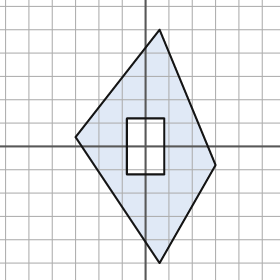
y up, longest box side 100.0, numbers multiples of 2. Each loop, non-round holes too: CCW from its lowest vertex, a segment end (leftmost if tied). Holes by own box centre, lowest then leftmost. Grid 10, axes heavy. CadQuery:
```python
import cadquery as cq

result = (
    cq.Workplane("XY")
    .moveTo(6.0, -50.0)
    .lineTo(30.0, -8.0)
    .lineTo(6.0, 50.0)
    .lineTo(-30.0, 4.0)
    .close()
    .moveTo(-8.0, -12.0)
    .lineTo(8.0, -12.0)
    .lineTo(8.0, 12.0)
    .lineTo(-8.0, 12.0)
    .close()
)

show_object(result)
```